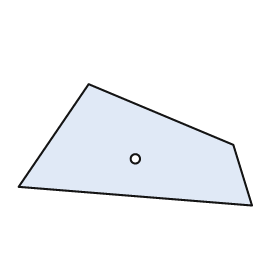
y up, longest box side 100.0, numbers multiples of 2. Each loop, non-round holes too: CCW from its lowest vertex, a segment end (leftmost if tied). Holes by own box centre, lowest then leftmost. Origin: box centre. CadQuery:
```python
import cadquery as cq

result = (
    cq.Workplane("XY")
    .moveTo(50.0, -26.0)
    .lineTo(42.0, 0.0)
    .lineTo(-20.0, 26.0)
    .lineTo(-50.0, -18.0)
    .close()
    .moveTo(0.0, -6.0)
    .circle(2.0)
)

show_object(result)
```